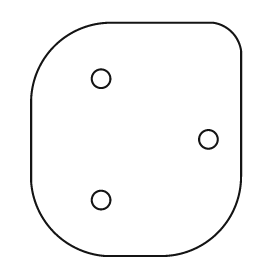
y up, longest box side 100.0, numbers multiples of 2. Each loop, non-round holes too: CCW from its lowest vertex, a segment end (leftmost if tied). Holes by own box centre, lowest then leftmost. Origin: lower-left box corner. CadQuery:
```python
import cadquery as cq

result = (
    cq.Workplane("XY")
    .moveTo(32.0, 0.0)
    .lineTo(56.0, 0.0)
    .threePointArc((80.0, 10.0), (90.0, 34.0))
    .lineTo(90.0, 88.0)
    .threePointArc((86.0, 96.0), (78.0, 100.0))
    .lineTo(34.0, 100.0)
    .threePointArc((10.0, 90.0), (0.0, 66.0))
    .lineTo(0.0, 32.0)
    .threePointArc((10.0, 10.0), (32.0, 0.0))
    .close()
    .moveTo(30.0, 24.0)
    .circle(4.0)
    .moveTo(76.0, 50.0)
    .circle(4.0)
    .moveTo(30.0, 76.0)
    .circle(4.0)
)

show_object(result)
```